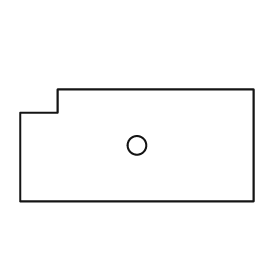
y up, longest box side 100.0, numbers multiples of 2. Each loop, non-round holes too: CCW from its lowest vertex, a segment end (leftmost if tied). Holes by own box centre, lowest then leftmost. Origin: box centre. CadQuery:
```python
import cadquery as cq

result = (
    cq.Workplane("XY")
    .moveTo(-50.0, -24.0)
    .lineTo(50.0, -24.0)
    .lineTo(50.0, 24.0)
    .lineTo(-34.0, 24.0)
    .lineTo(-34.0, 14.0)
    .lineTo(-50.0, 14.0)
    .close()
    .moveTo(0.0, 0.0)
    .circle(4.0)
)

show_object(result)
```